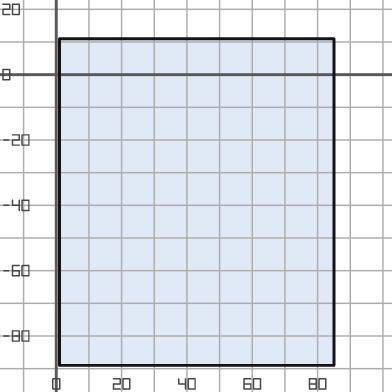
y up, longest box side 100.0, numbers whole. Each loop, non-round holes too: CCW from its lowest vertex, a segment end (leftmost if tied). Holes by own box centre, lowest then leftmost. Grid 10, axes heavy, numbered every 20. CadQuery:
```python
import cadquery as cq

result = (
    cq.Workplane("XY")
    .moveTo(1.0, -89.0)
    .lineTo(85.0, -89.0)
    .lineTo(85.0, 11.0)
    .lineTo(1.0, 11.0)
    .close()
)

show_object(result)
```